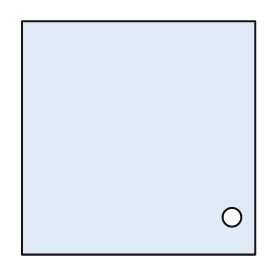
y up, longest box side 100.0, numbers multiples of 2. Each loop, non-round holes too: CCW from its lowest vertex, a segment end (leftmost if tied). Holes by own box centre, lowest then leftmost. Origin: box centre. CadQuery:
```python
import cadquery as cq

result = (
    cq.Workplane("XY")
    .moveTo(-50.0, -50.0)
    .lineTo(50.0, -50.0)
    .lineTo(50.0, 50.0)
    .lineTo(-50.0, 50.0)
    .close()
    .moveTo(40.0, -34.0)
    .circle(4.0)
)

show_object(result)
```